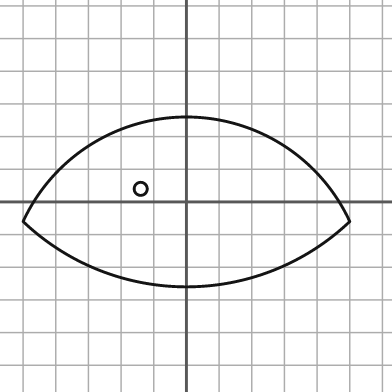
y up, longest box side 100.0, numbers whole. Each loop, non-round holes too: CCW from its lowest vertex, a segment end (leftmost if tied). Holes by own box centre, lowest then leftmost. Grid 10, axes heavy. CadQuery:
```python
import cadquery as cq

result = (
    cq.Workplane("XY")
    .moveTo(-50.0, -6.0)
    .threePointArc((0.0, -26.0), (50.0, -6.0))
    .threePointArc((0.0, 26.0), (-50.0, -6.0))
    .close()
    .moveTo(-14.0, 4.0)
    .circle(2.0)
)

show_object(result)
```